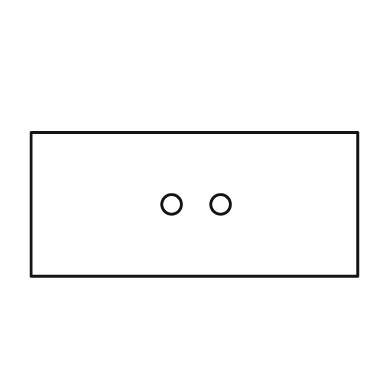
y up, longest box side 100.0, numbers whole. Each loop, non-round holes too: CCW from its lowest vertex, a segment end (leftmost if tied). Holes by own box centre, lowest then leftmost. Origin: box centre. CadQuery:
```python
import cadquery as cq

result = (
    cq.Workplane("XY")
    .moveTo(-50.0, -22.0)
    .lineTo(50.0, -22.0)
    .lineTo(50.0, 22.0)
    .lineTo(-50.0, 22.0)
    .close()
    .moveTo(-7.0, 0.0)
    .circle(3.0)
    .moveTo(8.0, 0.0)
    .circle(3.0)
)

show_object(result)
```